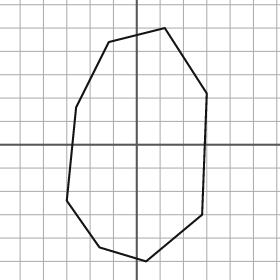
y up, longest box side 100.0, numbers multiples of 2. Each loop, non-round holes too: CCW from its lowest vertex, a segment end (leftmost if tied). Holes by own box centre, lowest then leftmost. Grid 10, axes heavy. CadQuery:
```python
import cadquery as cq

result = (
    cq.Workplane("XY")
    .moveTo(4.0, -50.0)
    .lineTo(28.0, -30.0)
    .lineTo(30.0, 22.0)
    .lineTo(12.0, 50.0)
    .lineTo(-12.0, 44.0)
    .lineTo(-26.0, 16.0)
    .lineTo(-30.0, -24.0)
    .lineTo(-16.0, -44.0)
    .close()
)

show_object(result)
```